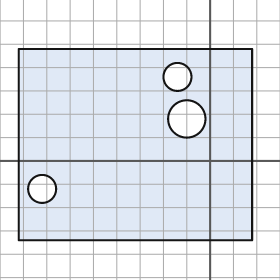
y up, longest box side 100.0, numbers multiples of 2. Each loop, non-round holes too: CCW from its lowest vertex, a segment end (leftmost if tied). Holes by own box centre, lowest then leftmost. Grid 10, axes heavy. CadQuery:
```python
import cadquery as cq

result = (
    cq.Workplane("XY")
    .moveTo(-82.0, -34.0)
    .lineTo(18.0, -34.0)
    .lineTo(18.0, 48.0)
    .lineTo(-82.0, 48.0)
    .close()
    .moveTo(-72.0, -12.0)
    .circle(6.0)
    .moveTo(-10.0, 18.0)
    .circle(8.0)
    .moveTo(-14.0, 36.0)
    .circle(6.0)
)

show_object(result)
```